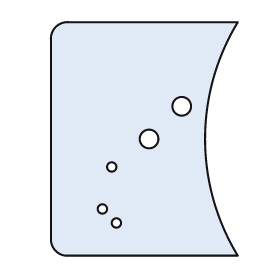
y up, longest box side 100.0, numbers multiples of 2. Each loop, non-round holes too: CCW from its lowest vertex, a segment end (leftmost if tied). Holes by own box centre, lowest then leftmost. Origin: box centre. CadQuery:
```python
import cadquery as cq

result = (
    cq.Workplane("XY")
    .moveTo(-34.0, -50.0)
    .lineTo(40.0, -50.0)
    .threePointArc((26.0, 0.0), (40.0, 50.0))
    .lineTo(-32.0, 50.0)
    .threePointArc((-38.0, 48.0), (-40.0, 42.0))
    .lineTo(-40.0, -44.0)
    .threePointArc((-38.0, -48.0), (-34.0, -50.0))
    .close()
    .moveTo(-12.0, -36.0)
    .circle(2.0)
    .moveTo(-18.0, -30.0)
    .circle(2.0)
    .moveTo(-14.0, -12.0)
    .circle(2.0)
    .moveTo(2.0, 0.0)
    .circle(4.0)
    .moveTo(16.0, 14.0)
    .circle(4.0)
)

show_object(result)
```